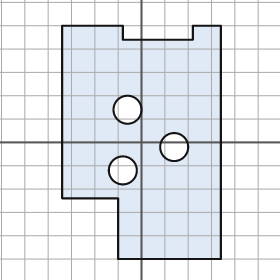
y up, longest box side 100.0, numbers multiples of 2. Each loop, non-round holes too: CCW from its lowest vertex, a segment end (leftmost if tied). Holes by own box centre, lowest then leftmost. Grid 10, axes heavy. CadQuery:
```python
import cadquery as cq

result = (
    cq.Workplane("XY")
    .moveTo(-10.0, -50.0)
    .lineTo(34.0, -50.0)
    .lineTo(34.0, 50.0)
    .lineTo(22.0, 50.0)
    .lineTo(22.0, 44.0)
    .lineTo(-8.0, 44.0)
    .lineTo(-8.0, 50.0)
    .lineTo(-34.0, 50.0)
    .lineTo(-34.0, -24.0)
    .lineTo(-10.0, -24.0)
    .close()
    .moveTo(-8.0, -12.0)
    .circle(6.0)
    .moveTo(14.0, -2.0)
    .circle(6.0)
    .moveTo(-6.0, 14.0)
    .circle(6.0)
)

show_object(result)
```